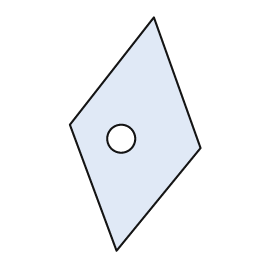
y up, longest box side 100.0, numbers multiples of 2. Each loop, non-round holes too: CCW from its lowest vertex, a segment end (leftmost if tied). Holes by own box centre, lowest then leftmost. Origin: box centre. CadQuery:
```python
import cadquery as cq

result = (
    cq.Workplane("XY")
    .moveTo(-8.0, -50.0)
    .lineTo(28.0, -6.0)
    .lineTo(8.0, 50.0)
    .lineTo(-28.0, 4.0)
    .close()
    .moveTo(-6.0, -2.0)
    .circle(6.0)
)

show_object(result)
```